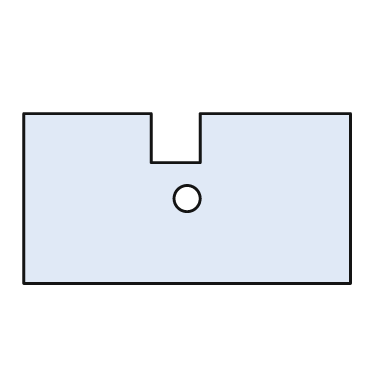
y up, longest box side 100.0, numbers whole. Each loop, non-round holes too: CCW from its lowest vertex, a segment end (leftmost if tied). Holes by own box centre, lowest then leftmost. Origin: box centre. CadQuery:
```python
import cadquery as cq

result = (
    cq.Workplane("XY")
    .moveTo(-50.0, -26.0)
    .lineTo(50.0, -26.0)
    .lineTo(50.0, 26.0)
    .lineTo(4.0, 26.0)
    .lineTo(4.0, 11.0)
    .lineTo(-11.0, 11.0)
    .lineTo(-11.0, 26.0)
    .lineTo(-50.0, 26.0)
    .close()
    .moveTo(0.0, 0.0)
    .circle(4.0)
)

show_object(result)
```